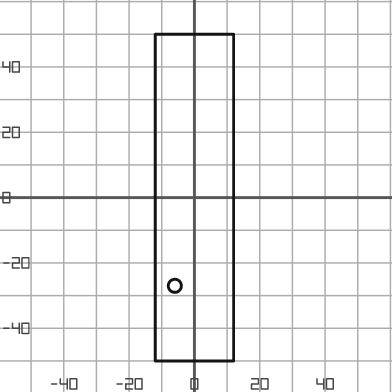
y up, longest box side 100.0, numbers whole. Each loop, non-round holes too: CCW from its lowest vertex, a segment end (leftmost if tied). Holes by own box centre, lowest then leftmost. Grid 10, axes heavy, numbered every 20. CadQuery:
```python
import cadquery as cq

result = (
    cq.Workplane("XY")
    .moveTo(-12.0, -50.0)
    .lineTo(12.0, -50.0)
    .lineTo(12.0, 50.0)
    .lineTo(-12.0, 50.0)
    .close()
    .moveTo(-6.0, -27.0)
    .circle(2.0)
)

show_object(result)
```